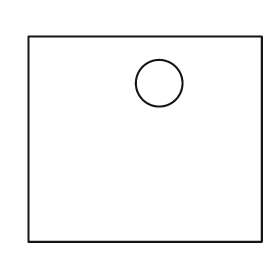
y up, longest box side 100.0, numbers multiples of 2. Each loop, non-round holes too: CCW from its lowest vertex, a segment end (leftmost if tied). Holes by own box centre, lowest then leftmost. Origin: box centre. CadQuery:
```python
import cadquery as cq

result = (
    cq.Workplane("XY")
    .moveTo(-50.0, -44.0)
    .lineTo(50.0, -44.0)
    .lineTo(50.0, 44.0)
    .lineTo(-50.0, 44.0)
    .close()
    .moveTo(6.0, 24.0)
    .circle(10.0)
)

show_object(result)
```